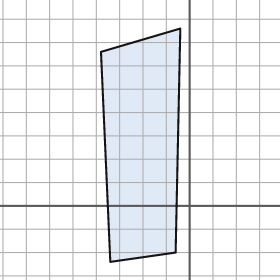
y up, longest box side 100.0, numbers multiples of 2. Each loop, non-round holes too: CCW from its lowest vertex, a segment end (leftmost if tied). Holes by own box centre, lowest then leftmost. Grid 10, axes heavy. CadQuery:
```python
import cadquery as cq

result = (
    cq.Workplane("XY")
    .moveTo(-34.0, -24.0)
    .lineTo(-6.0, -20.0)
    .lineTo(-4.0, 76.0)
    .lineTo(-38.0, 66.0)
    .close()
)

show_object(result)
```